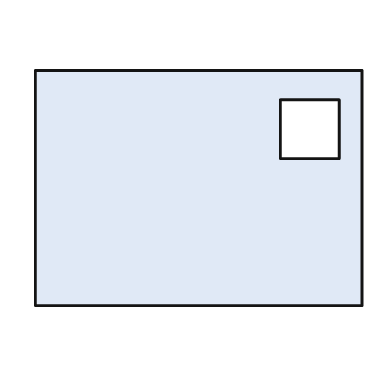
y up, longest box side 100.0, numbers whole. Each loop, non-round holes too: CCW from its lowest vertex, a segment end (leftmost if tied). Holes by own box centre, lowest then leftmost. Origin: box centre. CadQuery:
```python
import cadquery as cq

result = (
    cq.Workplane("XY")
    .moveTo(-50.0, -36.0)
    .lineTo(50.0, -36.0)
    .lineTo(50.0, 36.0)
    .lineTo(-50.0, 36.0)
    .close()
    .moveTo(25.0, 9.0)
    .lineTo(43.0, 9.0)
    .lineTo(43.0, 27.0)
    .lineTo(25.0, 27.0)
    .close()
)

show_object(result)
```